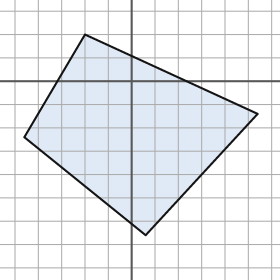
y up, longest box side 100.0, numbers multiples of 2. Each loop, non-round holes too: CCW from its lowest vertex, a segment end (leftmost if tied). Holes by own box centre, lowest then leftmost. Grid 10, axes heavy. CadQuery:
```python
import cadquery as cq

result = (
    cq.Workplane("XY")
    .moveTo(6.0, -66.0)
    .lineTo(54.0, -14.0)
    .lineTo(-20.0, 20.0)
    .lineTo(-46.0, -24.0)
    .close()
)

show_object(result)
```